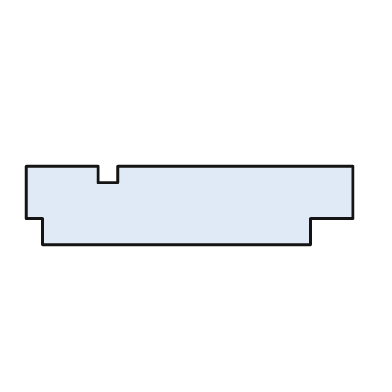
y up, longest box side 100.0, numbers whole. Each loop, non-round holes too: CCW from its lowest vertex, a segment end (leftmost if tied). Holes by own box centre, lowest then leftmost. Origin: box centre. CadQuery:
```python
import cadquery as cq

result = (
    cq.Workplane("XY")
    .moveTo(-45.0, -12.0)
    .lineTo(37.0, -12.0)
    .lineTo(37.0, -4.0)
    .lineTo(50.0, -4.0)
    .lineTo(50.0, 12.0)
    .lineTo(-22.0, 12.0)
    .lineTo(-22.0, 7.0)
    .lineTo(-28.0, 7.0)
    .lineTo(-28.0, 12.0)
    .lineTo(-50.0, 12.0)
    .lineTo(-50.0, -4.0)
    .lineTo(-45.0, -4.0)
    .close()
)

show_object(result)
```